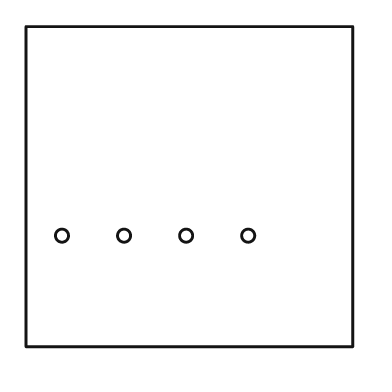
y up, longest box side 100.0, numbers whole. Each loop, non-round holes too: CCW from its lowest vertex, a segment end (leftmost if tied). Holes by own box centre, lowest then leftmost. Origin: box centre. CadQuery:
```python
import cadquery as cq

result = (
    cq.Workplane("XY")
    .moveTo(-50.0, -49.0)
    .lineTo(50.0, -49.0)
    .lineTo(50.0, 49.0)
    .lineTo(-50.0, 49.0)
    .close()
    .moveTo(-39.0, -15.0)
    .circle(2.0)
    .moveTo(-20.0, -15.0)
    .circle(2.0)
    .moveTo(-1.0, -15.0)
    .circle(2.0)
    .moveTo(18.0, -15.0)
    .circle(2.0)
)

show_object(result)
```